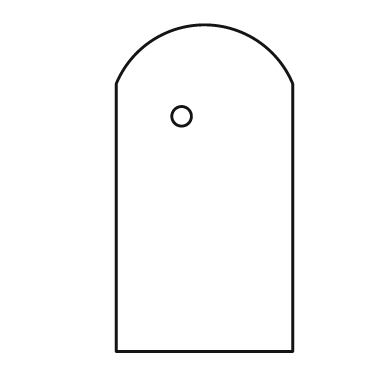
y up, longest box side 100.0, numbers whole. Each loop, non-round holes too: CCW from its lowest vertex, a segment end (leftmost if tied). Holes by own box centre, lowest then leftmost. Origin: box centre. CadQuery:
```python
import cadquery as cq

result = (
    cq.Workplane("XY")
    .moveTo(-27.0, -50.0)
    .lineTo(27.0, -50.0)
    .lineTo(27.0, 32.0)
    .threePointArc((0.0, 50.0), (-27.0, 32.0))
    .close()
    .moveTo(-7.0, 22.0)
    .circle(3.0)
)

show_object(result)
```